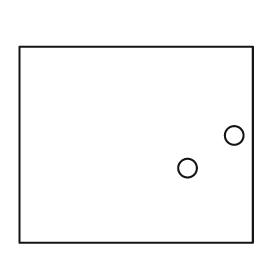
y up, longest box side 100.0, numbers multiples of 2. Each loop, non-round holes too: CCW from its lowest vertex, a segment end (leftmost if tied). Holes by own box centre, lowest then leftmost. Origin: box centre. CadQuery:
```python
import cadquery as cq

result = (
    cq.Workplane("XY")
    .moveTo(-50.0, -42.0)
    .lineTo(50.0, -42.0)
    .lineTo(50.0, 42.0)
    .lineTo(-50.0, 42.0)
    .close()
    .moveTo(22.0, -10.0)
    .circle(4.0)
    .moveTo(42.0, 4.0)
    .circle(4.0)
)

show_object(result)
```